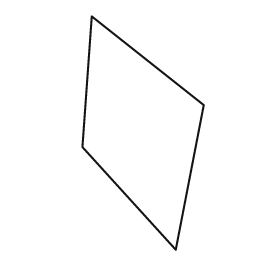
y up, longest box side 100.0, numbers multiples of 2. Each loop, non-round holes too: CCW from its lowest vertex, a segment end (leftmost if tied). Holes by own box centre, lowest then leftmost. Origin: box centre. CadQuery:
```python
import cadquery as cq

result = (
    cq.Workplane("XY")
    .moveTo(14.0, -50.0)
    .lineTo(26.0, 12.0)
    .lineTo(-22.0, 50.0)
    .lineTo(-26.0, -6.0)
    .close()
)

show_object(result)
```